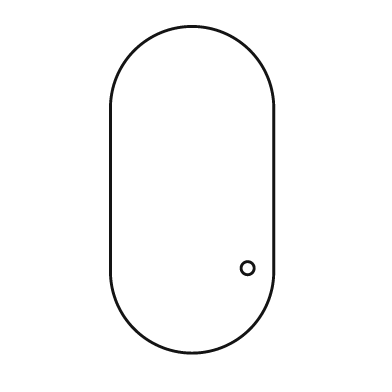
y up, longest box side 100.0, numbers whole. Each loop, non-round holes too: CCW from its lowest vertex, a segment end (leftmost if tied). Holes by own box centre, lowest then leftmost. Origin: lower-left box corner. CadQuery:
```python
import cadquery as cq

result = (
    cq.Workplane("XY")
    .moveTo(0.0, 25.0)
    .threePointArc((25.0, 0.0), (50.0, 25.0))
    .lineTo(50.0, 75.0)
    .threePointArc((25.0, 100.0), (0.0, 75.0))
    .close()
    .moveTo(42.0, 26.0)
    .circle(2.0)
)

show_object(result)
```